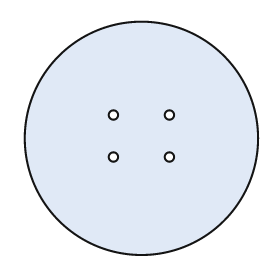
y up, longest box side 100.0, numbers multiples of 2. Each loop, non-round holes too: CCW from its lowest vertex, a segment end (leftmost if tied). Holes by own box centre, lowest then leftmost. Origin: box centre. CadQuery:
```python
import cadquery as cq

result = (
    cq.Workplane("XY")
    .moveTo(0.0, 0.0)
    .circle(50.0)
    .moveTo(-12.0, -8.0)
    .circle(2.0)
    .moveTo(12.0, -8.0)
    .circle(2.0)
    .moveTo(-12.0, 10.0)
    .circle(2.0)
    .moveTo(12.0, 10.0)
    .circle(2.0)
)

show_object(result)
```